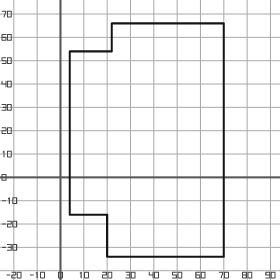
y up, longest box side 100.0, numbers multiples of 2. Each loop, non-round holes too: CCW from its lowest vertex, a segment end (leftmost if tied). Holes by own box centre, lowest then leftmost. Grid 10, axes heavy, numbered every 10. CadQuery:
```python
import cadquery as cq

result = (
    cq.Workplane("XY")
    .moveTo(20.0, -34.0)
    .lineTo(70.0, -34.0)
    .lineTo(70.0, 66.0)
    .lineTo(22.0, 66.0)
    .lineTo(22.0, 54.0)
    .lineTo(4.0, 54.0)
    .lineTo(4.0, -16.0)
    .lineTo(20.0, -16.0)
    .close()
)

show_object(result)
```